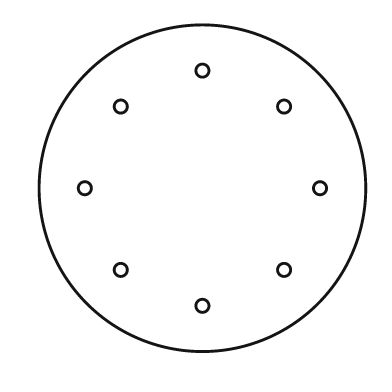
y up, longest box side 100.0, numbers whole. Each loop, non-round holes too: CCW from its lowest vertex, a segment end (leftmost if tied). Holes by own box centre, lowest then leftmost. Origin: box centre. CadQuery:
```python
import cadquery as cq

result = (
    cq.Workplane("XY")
    .moveTo(0.0, 0.0)
    .circle(50.0)
    .moveTo(0.0, -36.0)
    .circle(2.0)
    .moveTo(-25.0, -25.0)
    .circle(2.0)
    .moveTo(25.0, -25.0)
    .circle(2.0)
    .moveTo(-36.0, 0.0)
    .circle(2.0)
    .moveTo(36.0, 0.0)
    .circle(2.0)
    .moveTo(-25.0, 25.0)
    .circle(2.0)
    .moveTo(25.0, 25.0)
    .circle(2.0)
    .moveTo(0.0, 36.0)
    .circle(2.0)
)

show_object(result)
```